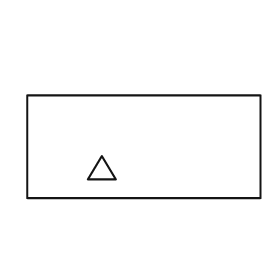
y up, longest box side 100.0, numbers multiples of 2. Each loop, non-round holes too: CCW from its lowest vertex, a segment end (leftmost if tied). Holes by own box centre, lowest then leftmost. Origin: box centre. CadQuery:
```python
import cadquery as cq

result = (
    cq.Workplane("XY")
    .moveTo(-50.0, -22.0)
    .lineTo(50.0, -22.0)
    .lineTo(50.0, 22.0)
    .lineTo(-50.0, 22.0)
    .close()
    .moveTo(-24.0, -14.0)
    .lineTo(-12.0, -14.0)
    .lineTo(-18.0, -4.0)
    .close()
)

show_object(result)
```